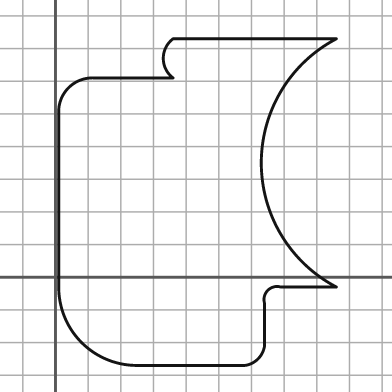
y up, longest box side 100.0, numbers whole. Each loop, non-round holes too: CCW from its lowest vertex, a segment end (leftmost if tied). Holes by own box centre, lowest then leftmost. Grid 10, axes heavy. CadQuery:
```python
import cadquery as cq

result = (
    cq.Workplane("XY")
    .moveTo(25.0, -27.0)
    .lineTo(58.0, -27.0)
    .threePointArc((62.0, -25.0), (64.0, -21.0))
    .lineTo(64.0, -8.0)
    .threePointArc((65.0, -4.0), (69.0, -3.0))
    .lineTo(86.0, -3.0)
    .threePointArc((63.0, 35.0), (86.0, 73.0))
    .lineTo(36.0, 73.0)
    .threePointArc((33.0, 67.0), (36.0, 61.0))
    .lineTo(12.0, 61.0)
    .threePointArc((4.0, 58.0), (1.0, 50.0))
    .lineTo(1.0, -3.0)
    .threePointArc((8.0, -20.0), (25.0, -27.0))
    .close()
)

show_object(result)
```